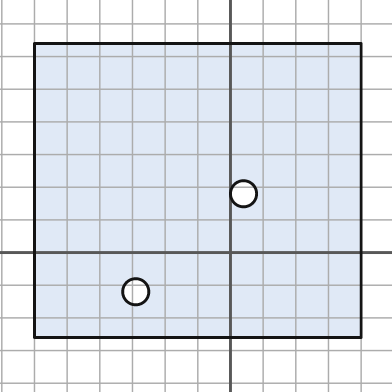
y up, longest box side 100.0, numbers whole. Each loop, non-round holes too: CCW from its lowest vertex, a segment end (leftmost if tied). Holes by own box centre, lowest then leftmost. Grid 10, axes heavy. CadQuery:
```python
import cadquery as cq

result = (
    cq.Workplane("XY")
    .moveTo(-60.0, -26.0)
    .lineTo(40.0, -26.0)
    .lineTo(40.0, 64.0)
    .lineTo(-60.0, 64.0)
    .close()
    .moveTo(-29.0, -12.0)
    .circle(4.0)
    .moveTo(4.0, 18.0)
    .circle(4.0)
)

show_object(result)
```